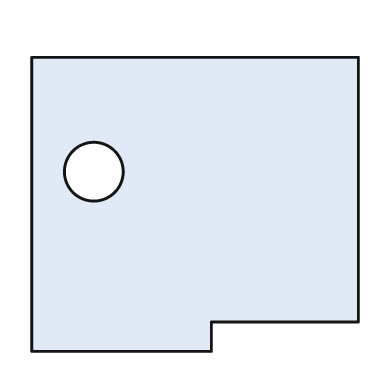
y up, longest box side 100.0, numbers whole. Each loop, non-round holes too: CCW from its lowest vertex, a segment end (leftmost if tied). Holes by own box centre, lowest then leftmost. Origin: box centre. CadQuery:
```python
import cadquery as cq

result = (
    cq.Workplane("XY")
    .moveTo(-50.0, -45.0)
    .lineTo(5.0, -45.0)
    .lineTo(5.0, -36.0)
    .lineTo(50.0, -36.0)
    .lineTo(50.0, 45.0)
    .lineTo(-50.0, 45.0)
    .close()
    .moveTo(-31.0, 10.0)
    .circle(9.0)
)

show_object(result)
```